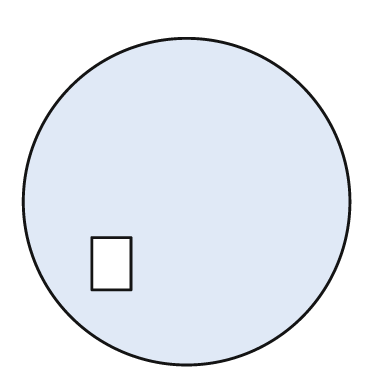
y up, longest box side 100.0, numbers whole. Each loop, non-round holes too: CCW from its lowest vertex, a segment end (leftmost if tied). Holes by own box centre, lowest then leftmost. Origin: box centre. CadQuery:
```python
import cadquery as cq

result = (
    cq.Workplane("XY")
    .moveTo(0.0, 0.0)
    .circle(50.0)
    .moveTo(-29.0, -27.0)
    .lineTo(-17.0, -27.0)
    .lineTo(-17.0, -11.0)
    .lineTo(-29.0, -11.0)
    .close()
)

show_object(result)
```